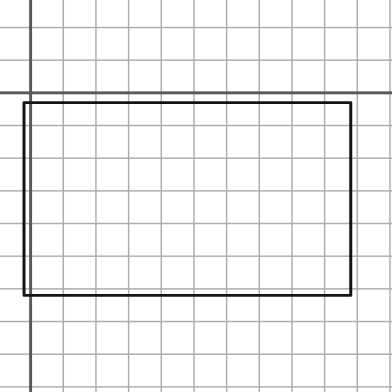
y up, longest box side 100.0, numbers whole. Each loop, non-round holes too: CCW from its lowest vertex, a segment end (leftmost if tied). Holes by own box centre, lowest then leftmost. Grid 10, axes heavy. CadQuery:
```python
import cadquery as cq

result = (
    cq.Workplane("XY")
    .moveTo(-2.0, -62.0)
    .lineTo(98.0, -62.0)
    .lineTo(98.0, -3.0)
    .lineTo(-2.0, -3.0)
    .close()
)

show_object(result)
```